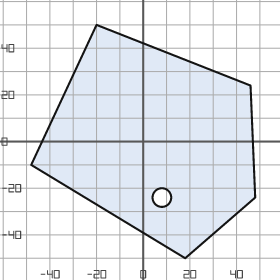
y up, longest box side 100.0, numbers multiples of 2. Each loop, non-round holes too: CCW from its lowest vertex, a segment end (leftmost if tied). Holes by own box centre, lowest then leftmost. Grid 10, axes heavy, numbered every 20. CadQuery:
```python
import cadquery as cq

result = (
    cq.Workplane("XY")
    .moveTo(18.0, -50.0)
    .lineTo(48.0, -24.0)
    .lineTo(46.0, 24.0)
    .lineTo(-20.0, 50.0)
    .lineTo(-48.0, -10.0)
    .close()
    .moveTo(8.0, -24.0)
    .circle(4.0)
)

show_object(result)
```